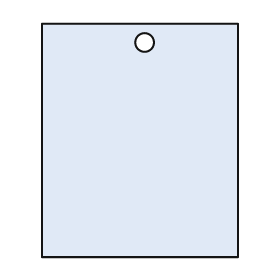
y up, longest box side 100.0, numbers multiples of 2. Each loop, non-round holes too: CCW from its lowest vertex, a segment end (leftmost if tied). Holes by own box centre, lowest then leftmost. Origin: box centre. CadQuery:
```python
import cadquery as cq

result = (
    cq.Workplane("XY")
    .moveTo(-42.0, -50.0)
    .lineTo(42.0, -50.0)
    .lineTo(42.0, 50.0)
    .lineTo(-42.0, 50.0)
    .close()
    .moveTo(2.0, 42.0)
    .circle(4.0)
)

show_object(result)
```